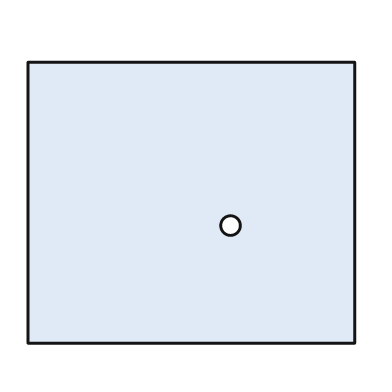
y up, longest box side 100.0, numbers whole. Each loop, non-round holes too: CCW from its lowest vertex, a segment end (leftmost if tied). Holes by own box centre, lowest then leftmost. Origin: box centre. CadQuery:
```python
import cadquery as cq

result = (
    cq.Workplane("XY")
    .moveTo(-50.0, -43.0)
    .lineTo(50.0, -43.0)
    .lineTo(50.0, 43.0)
    .lineTo(-50.0, 43.0)
    .close()
    .moveTo(12.0, -7.0)
    .circle(3.0)
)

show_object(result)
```